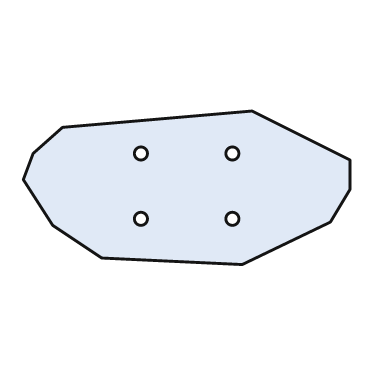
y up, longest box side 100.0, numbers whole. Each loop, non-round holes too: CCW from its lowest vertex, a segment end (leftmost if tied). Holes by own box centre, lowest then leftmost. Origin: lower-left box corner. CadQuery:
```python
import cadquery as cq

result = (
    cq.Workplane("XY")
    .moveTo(67.0, 0.0)
    .lineTo(94.0, 13.0)
    .lineTo(100.0, 23.0)
    .lineTo(100.0, 32.0)
    .lineTo(70.0, 47.0)
    .lineTo(12.0, 42.0)
    .lineTo(3.0, 34.0)
    .lineTo(0.0, 26.0)
    .lineTo(9.0, 12.0)
    .lineTo(24.0, 2.0)
    .close()
    .moveTo(36.0, 14.0)
    .circle(2.0)
    .moveTo(64.0, 14.0)
    .circle(2.0)
    .moveTo(36.0, 34.0)
    .circle(2.0)
    .moveTo(64.0, 34.0)
    .circle(2.0)
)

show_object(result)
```